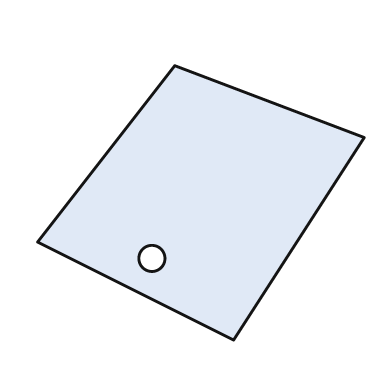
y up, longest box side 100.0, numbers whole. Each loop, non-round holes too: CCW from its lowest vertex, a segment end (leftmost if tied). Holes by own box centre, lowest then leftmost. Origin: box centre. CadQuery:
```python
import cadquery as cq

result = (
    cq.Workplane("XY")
    .moveTo(10.0, -42.0)
    .lineTo(50.0, 20.0)
    .lineTo(-8.0, 42.0)
    .lineTo(-50.0, -12.0)
    .close()
    .moveTo(-15.0, -17.0)
    .circle(4.0)
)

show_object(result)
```